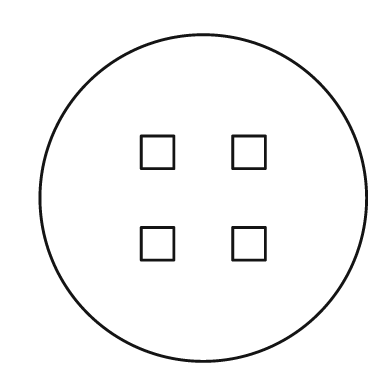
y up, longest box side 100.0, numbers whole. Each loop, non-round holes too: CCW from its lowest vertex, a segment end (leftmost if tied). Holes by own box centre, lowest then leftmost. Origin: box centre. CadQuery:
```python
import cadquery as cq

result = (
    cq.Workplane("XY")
    .moveTo(0.0, 0.0)
    .circle(50.0)
    .moveTo(-19.0, -19.0)
    .lineTo(-9.0, -19.0)
    .lineTo(-9.0, -9.0)
    .lineTo(-19.0, -9.0)
    .close()
    .moveTo(9.0, -19.0)
    .lineTo(19.0, -19.0)
    .lineTo(19.0, -9.0)
    .lineTo(9.0, -9.0)
    .close()
    .moveTo(-19.0, 9.0)
    .lineTo(-9.0, 9.0)
    .lineTo(-9.0, 19.0)
    .lineTo(-19.0, 19.0)
    .close()
    .moveTo(9.0, 9.0)
    .lineTo(19.0, 9.0)
    .lineTo(19.0, 19.0)
    .lineTo(9.0, 19.0)
    .close()
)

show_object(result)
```